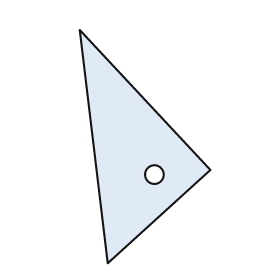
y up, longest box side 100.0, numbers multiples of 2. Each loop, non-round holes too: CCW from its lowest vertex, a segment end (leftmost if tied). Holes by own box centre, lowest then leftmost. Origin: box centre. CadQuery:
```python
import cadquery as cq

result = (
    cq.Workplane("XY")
    .moveTo(-16.0, -50.0)
    .lineTo(28.0, -10.0)
    .lineTo(-28.0, 50.0)
    .close()
    .moveTo(4.0, -12.0)
    .circle(4.0)
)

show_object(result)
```